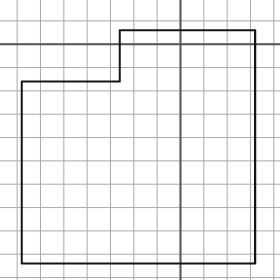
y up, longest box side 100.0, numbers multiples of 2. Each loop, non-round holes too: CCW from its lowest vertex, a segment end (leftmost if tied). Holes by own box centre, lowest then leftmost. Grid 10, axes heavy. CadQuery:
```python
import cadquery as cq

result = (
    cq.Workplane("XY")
    .moveTo(-68.0, -94.0)
    .lineTo(32.0, -94.0)
    .lineTo(32.0, 6.0)
    .lineTo(-26.0, 6.0)
    .lineTo(-26.0, -16.0)
    .lineTo(-68.0, -16.0)
    .close()
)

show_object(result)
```